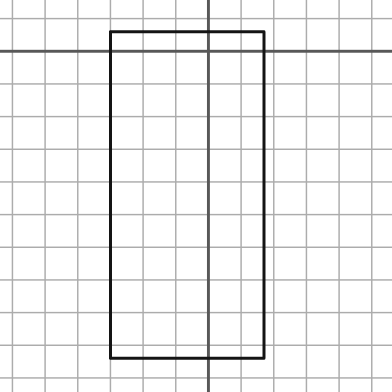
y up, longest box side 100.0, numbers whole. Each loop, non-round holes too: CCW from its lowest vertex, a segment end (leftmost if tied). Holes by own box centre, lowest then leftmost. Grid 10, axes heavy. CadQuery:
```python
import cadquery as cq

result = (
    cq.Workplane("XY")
    .moveTo(-30.0, -94.0)
    .lineTo(17.0, -94.0)
    .lineTo(17.0, 6.0)
    .lineTo(-30.0, 6.0)
    .close()
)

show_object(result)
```